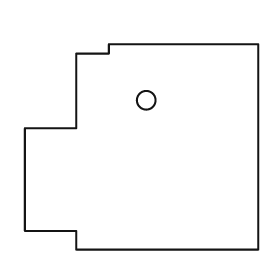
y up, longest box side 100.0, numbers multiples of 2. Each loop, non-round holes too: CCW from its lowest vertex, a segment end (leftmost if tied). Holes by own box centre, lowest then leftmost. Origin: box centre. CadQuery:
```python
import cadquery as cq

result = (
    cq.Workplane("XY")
    .moveTo(-28.0, -44.0)
    .lineTo(50.0, -44.0)
    .lineTo(50.0, 44.0)
    .lineTo(-14.0, 44.0)
    .lineTo(-14.0, 40.0)
    .lineTo(-28.0, 40.0)
    .lineTo(-28.0, 8.0)
    .lineTo(-50.0, 8.0)
    .lineTo(-50.0, -36.0)
    .lineTo(-28.0, -36.0)
    .close()
    .moveTo(2.0, 20.0)
    .circle(4.0)
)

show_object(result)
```